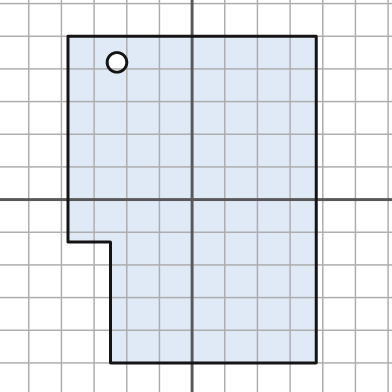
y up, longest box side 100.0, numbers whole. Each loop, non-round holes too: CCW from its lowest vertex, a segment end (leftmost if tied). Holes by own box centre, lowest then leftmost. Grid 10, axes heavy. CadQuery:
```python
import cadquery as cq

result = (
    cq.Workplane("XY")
    .moveTo(-25.0, -50.0)
    .lineTo(38.0, -50.0)
    .lineTo(38.0, 50.0)
    .lineTo(-38.0, 50.0)
    .lineTo(-38.0, -13.0)
    .lineTo(-25.0, -13.0)
    .close()
    .moveTo(-23.0, 42.0)
    .circle(3.0)
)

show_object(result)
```